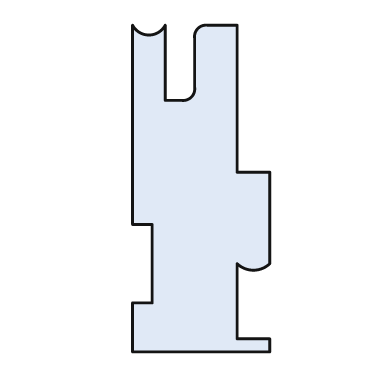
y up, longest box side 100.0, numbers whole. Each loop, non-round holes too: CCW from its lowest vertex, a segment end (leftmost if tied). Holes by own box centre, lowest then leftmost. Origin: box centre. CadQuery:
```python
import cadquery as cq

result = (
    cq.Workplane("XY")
    .moveTo(-21.0, -50.0)
    .lineTo(21.0, -50.0)
    .lineTo(21.0, -46.0)
    .lineTo(11.0, -46.0)
    .lineTo(11.0, -23.0)
    .threePointArc((16.0, -25.0), (21.0, -23.0))
    .lineTo(21.0, 5.0)
    .lineTo(11.0, 5.0)
    .lineTo(11.0, 50.0)
    .lineTo(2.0, 50.0)
    .threePointArc((-1.0, 49.0), (-2.0, 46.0))
    .lineTo(-2.0, 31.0)
    .threePointArc((-3.0, 28.0), (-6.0, 27.0))
    .lineTo(-11.0, 27.0)
    .lineTo(-11.0, 50.0)
    .threePointArc((-16.0, 47.0), (-21.0, 50.0))
    .lineTo(-21.0, -11.0)
    .lineTo(-15.0, -11.0)
    .lineTo(-15.0, -35.0)
    .lineTo(-21.0, -35.0)
    .close()
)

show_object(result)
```